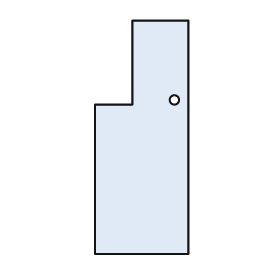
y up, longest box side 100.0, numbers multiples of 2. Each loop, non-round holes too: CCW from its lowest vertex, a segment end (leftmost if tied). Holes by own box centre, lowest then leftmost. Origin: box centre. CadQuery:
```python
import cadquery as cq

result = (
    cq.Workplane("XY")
    .moveTo(-20.0, -50.0)
    .lineTo(20.0, -50.0)
    .lineTo(20.0, 50.0)
    .lineTo(-4.0, 50.0)
    .lineTo(-4.0, 14.0)
    .lineTo(-20.0, 14.0)
    .close()
    .moveTo(14.0, 16.0)
    .circle(2.0)
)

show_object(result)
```